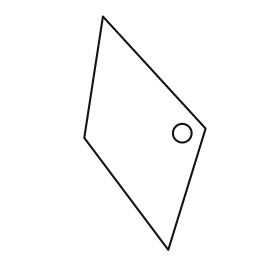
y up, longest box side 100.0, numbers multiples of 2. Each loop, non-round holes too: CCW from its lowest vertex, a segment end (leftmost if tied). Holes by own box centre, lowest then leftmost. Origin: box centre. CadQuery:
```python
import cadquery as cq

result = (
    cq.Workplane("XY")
    .moveTo(10.0, -50.0)
    .lineTo(26.0, 2.0)
    .lineTo(-18.0, 50.0)
    .lineTo(-26.0, -2.0)
    .close()
    .moveTo(16.0, 0.0)
    .circle(4.0)
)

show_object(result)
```